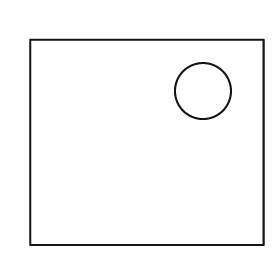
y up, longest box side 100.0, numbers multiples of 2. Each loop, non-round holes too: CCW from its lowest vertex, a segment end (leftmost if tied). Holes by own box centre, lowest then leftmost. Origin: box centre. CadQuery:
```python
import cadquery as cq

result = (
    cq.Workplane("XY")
    .moveTo(-50.0, -44.0)
    .lineTo(50.0, -44.0)
    .lineTo(50.0, 44.0)
    .lineTo(-50.0, 44.0)
    .close()
    .moveTo(24.0, 22.0)
    .circle(12.0)
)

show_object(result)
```